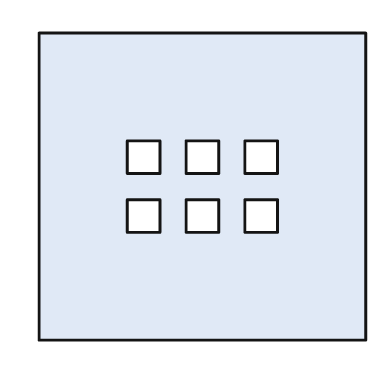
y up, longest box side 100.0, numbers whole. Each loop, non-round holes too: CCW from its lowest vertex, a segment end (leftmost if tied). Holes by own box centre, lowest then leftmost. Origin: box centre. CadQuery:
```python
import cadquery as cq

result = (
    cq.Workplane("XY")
    .moveTo(-50.0, -47.0)
    .lineTo(50.0, -47.0)
    .lineTo(50.0, 47.0)
    .lineTo(-50.0, 47.0)
    .close()
    .moveTo(-23.0, -14.0)
    .lineTo(-13.0, -14.0)
    .lineTo(-13.0, -4.0)
    .lineTo(-23.0, -4.0)
    .close()
    .moveTo(-5.0, -14.0)
    .lineTo(5.0, -14.0)
    .lineTo(5.0, -4.0)
    .lineTo(-5.0, -4.0)
    .close()
    .moveTo(13.0, -14.0)
    .lineTo(23.0, -14.0)
    .lineTo(23.0, -4.0)
    .lineTo(13.0, -4.0)
    .close()
    .moveTo(-23.0, 4.0)
    .lineTo(-13.0, 4.0)
    .lineTo(-13.0, 14.0)
    .lineTo(-23.0, 14.0)
    .close()
    .moveTo(-5.0, 4.0)
    .lineTo(5.0, 4.0)
    .lineTo(5.0, 14.0)
    .lineTo(-5.0, 14.0)
    .close()
    .moveTo(13.0, 4.0)
    .lineTo(23.0, 4.0)
    .lineTo(23.0, 14.0)
    .lineTo(13.0, 14.0)
    .close()
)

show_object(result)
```